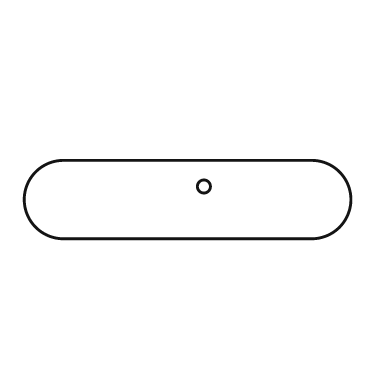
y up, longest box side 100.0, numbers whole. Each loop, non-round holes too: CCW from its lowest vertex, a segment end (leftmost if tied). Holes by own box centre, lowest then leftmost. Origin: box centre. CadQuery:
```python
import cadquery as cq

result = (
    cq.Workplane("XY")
    .moveTo(-38.0, -12.0)
    .lineTo(38.0, -12.0)
    .threePointArc((50.0, 0.0), (38.0, 12.0))
    .lineTo(-38.0, 12.0)
    .threePointArc((-50.0, 0.0), (-38.0, -12.0))
    .close()
    .moveTo(5.0, 4.0)
    .circle(2.0)
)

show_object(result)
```